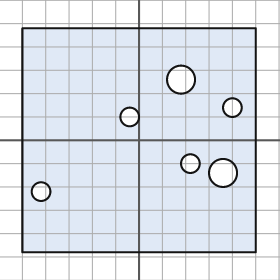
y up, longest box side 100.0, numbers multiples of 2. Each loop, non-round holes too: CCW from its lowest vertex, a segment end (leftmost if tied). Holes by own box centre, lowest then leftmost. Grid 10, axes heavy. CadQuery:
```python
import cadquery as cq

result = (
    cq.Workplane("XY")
    .moveTo(-50.0, -48.0)
    .lineTo(50.0, -48.0)
    .lineTo(50.0, 48.0)
    .lineTo(-50.0, 48.0)
    .close()
    .moveTo(-42.0, -22.0)
    .circle(4.0)
    .moveTo(36.0, -14.0)
    .circle(6.0)
    .moveTo(22.0, -10.0)
    .circle(4.0)
    .moveTo(-4.0, 10.0)
    .circle(4.0)
    .moveTo(40.0, 14.0)
    .circle(4.0)
    .moveTo(18.0, 26.0)
    .circle(6.0)
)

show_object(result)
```